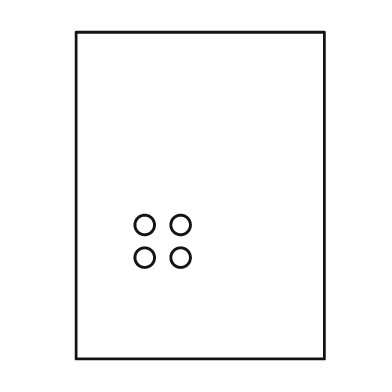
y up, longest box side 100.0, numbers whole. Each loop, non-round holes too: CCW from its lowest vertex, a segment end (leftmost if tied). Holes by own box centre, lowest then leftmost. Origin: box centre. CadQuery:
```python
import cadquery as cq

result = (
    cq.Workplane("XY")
    .moveTo(-38.0, -50.0)
    .lineTo(38.0, -50.0)
    .lineTo(38.0, 50.0)
    .lineTo(-38.0, 50.0)
    .close()
    .moveTo(-17.0, -19.0)
    .circle(3.0)
    .moveTo(-6.0, -19.0)
    .circle(3.0)
    .moveTo(-17.0, -9.0)
    .circle(3.0)
    .moveTo(-6.0, -9.0)
    .circle(3.0)
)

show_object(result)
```